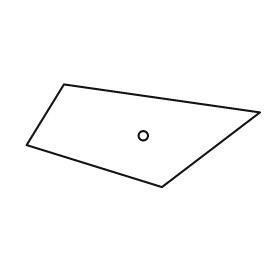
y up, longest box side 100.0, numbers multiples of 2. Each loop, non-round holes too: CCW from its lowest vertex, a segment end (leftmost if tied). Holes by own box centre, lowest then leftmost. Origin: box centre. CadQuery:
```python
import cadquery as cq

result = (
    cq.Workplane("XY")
    .moveTo(8.0, -22.0)
    .lineTo(50.0, 10.0)
    .lineTo(-34.0, 22.0)
    .lineTo(-50.0, -4.0)
    .close()
    .moveTo(0.0, 0.0)
    .circle(2.0)
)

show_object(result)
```